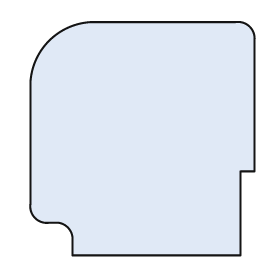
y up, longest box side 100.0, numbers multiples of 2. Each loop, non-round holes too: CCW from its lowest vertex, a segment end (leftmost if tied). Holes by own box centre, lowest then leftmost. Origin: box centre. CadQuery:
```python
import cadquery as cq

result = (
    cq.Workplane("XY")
    .moveTo(-30.0, -50.0)
    .lineTo(42.0, -50.0)
    .lineTo(42.0, -14.0)
    .lineTo(48.0, -14.0)
    .lineTo(48.0, 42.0)
    .threePointArc((46.0, 48.0), (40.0, 50.0))
    .lineTo(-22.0, 50.0)
    .threePointArc((-40.0, 42.0), (-48.0, 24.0))
    .lineTo(-48.0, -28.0)
    .threePointArc((-46.0, -34.0), (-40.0, -36.0))
    .lineTo(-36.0, -36.0)
    .threePointArc((-32.0, -38.0), (-30.0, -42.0))
    .close()
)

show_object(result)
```